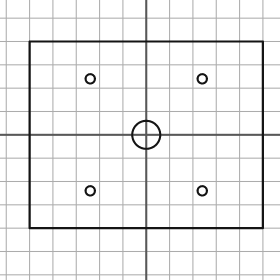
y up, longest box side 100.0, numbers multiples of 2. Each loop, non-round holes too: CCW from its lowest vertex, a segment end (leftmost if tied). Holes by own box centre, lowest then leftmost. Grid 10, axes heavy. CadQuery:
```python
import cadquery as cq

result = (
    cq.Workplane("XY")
    .moveTo(-50.0, -40.0)
    .lineTo(50.0, -40.0)
    .lineTo(50.0, 40.0)
    .lineTo(-50.0, 40.0)
    .close()
    .moveTo(-24.0, -24.0)
    .circle(2.0)
    .moveTo(24.0, -24.0)
    .circle(2.0)
    .moveTo(0.0, 0.0)
    .circle(6.0)
    .moveTo(-24.0, 24.0)
    .circle(2.0)
    .moveTo(24.0, 24.0)
    .circle(2.0)
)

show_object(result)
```